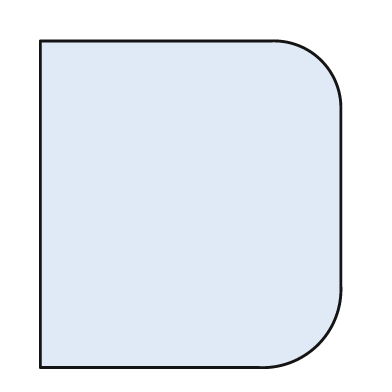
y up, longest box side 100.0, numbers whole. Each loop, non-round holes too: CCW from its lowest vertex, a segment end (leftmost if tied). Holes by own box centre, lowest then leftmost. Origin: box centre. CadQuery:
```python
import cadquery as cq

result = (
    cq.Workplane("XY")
    .moveTo(-46.0, -50.0)
    .lineTo(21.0, -50.0)
    .threePointArc((39.0, -43.0), (46.0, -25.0))
    .lineTo(46.0, 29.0)
    .threePointArc((40.0, 44.0), (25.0, 50.0))
    .lineTo(-46.0, 50.0)
    .close()
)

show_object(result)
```